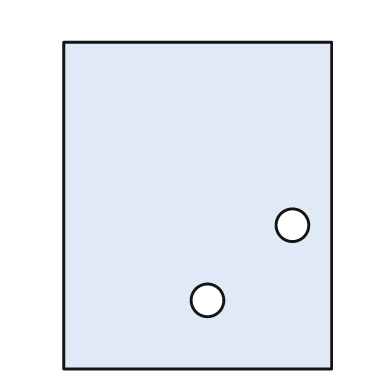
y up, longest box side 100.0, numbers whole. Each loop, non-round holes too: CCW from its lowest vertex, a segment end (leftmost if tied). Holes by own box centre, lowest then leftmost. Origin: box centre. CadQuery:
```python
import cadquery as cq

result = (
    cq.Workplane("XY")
    .moveTo(-41.0, -50.0)
    .lineTo(41.0, -50.0)
    .lineTo(41.0, 50.0)
    .lineTo(-41.0, 50.0)
    .close()
    .moveTo(3.0, -29.0)
    .circle(5.0)
    .moveTo(29.0, -6.0)
    .circle(5.0)
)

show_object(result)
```